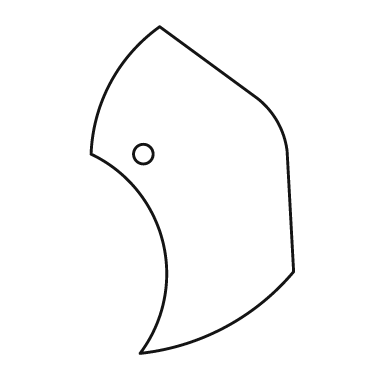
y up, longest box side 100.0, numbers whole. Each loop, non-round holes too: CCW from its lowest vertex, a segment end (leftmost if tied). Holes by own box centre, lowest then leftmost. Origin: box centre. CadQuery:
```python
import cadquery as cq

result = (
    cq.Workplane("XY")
    .moveTo(-16.0, -50.0)
    .threePointArc((10.0, -42.0), (31.0, -25.0))
    .lineTo(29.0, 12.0)
    .threePointArc((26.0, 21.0), (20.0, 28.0))
    .lineTo(-10.0, 50.0)
    .threePointArc((-25.0, 33.0), (-31.0, 11.0))
    .threePointArc((-9.0, -16.0), (-16.0, -50.0))
    .close()
    .moveTo(-15.0, 11.0)
    .circle(3.0)
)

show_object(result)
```